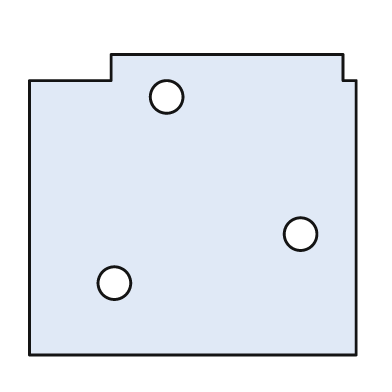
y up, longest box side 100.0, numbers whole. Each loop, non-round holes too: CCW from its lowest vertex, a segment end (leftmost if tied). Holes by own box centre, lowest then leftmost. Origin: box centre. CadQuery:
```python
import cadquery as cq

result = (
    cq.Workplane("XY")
    .moveTo(-50.0, -46.0)
    .lineTo(50.0, -46.0)
    .lineTo(50.0, 38.0)
    .lineTo(46.0, 38.0)
    .lineTo(46.0, 46.0)
    .lineTo(-25.0, 46.0)
    .lineTo(-25.0, 38.0)
    .lineTo(-50.0, 38.0)
    .close()
    .moveTo(-24.0, -24.0)
    .circle(5.0)
    .moveTo(33.0, -9.0)
    .circle(5.0)
    .moveTo(-8.0, 33.0)
    .circle(5.0)
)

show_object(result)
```